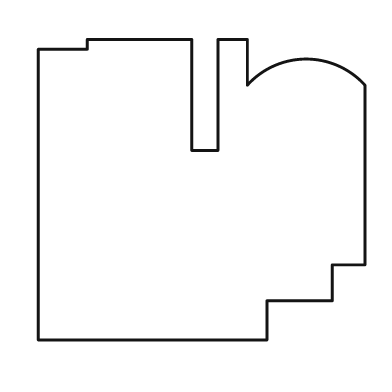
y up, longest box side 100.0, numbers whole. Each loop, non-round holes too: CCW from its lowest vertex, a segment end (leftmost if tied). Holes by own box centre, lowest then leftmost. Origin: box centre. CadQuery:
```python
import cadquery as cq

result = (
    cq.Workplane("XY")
    .moveTo(-50.0, -46.0)
    .lineTo(20.0, -46.0)
    .lineTo(20.0, -34.0)
    .lineTo(40.0, -34.0)
    .lineTo(40.0, -23.0)
    .lineTo(50.0, -23.0)
    .lineTo(50.0, 32.0)
    .threePointArc((32.0, 40.0), (14.0, 32.0))
    .lineTo(14.0, 46.0)
    .lineTo(5.0, 46.0)
    .lineTo(5.0, 12.0)
    .lineTo(-3.0, 12.0)
    .lineTo(-3.0, 46.0)
    .lineTo(-35.0, 46.0)
    .lineTo(-35.0, 43.0)
    .lineTo(-50.0, 43.0)
    .close()
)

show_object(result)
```